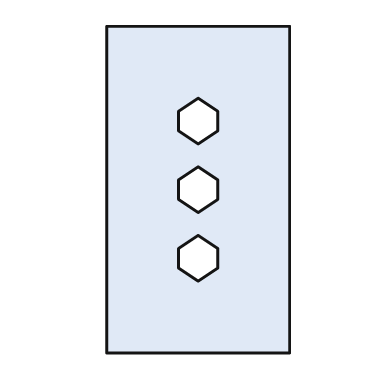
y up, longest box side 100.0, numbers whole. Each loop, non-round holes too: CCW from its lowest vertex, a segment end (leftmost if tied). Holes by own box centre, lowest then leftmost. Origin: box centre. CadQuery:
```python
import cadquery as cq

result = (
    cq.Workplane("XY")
    .moveTo(-28.0, -50.0)
    .lineTo(28.0, -50.0)
    .lineTo(28.0, 50.0)
    .lineTo(-28.0, 50.0)
    .close()
    .moveTo(0.0, -28.0)
    .lineTo(6.0, -24.0)
    .lineTo(6.0, -18.0)
    .lineTo(0.0, -14.0)
    .lineTo(-6.0, -18.0)
    .lineTo(-6.0, -24.0)
    .close()
    .moveTo(0.0, -7.0)
    .lineTo(6.0, -3.0)
    .lineTo(6.0, 3.0)
    .lineTo(0.0, 7.0)
    .lineTo(-6.0, 3.0)
    .lineTo(-6.0, -3.0)
    .close()
    .moveTo(0.0, 14.0)
    .lineTo(6.0, 18.0)
    .lineTo(6.0, 24.0)
    .lineTo(0.0, 28.0)
    .lineTo(-6.0, 24.0)
    .lineTo(-6.0, 18.0)
    .close()
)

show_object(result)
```